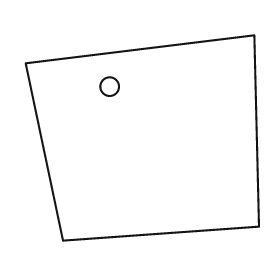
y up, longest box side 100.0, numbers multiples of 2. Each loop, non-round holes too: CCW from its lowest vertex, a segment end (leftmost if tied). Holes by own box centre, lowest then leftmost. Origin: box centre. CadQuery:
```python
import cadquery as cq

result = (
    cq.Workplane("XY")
    .moveTo(-34.0, -44.0)
    .lineTo(50.0, -38.0)
    .lineTo(48.0, 44.0)
    .lineTo(-50.0, 32.0)
    .close()
    .moveTo(-14.0, 22.0)
    .circle(4.0)
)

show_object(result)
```